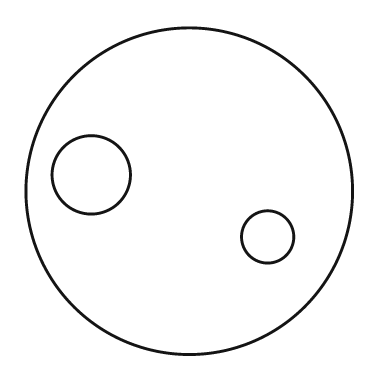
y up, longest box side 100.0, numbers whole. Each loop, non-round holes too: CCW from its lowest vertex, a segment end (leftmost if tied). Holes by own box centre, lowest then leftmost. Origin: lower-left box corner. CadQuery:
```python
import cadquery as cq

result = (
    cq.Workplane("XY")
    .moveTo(50.0, 50.0)
    .circle(50.0)
    .moveTo(74.0, 36.0)
    .circle(8.0)
    .moveTo(20.0, 55.0)
    .circle(12.0)
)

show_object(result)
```